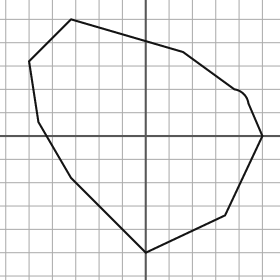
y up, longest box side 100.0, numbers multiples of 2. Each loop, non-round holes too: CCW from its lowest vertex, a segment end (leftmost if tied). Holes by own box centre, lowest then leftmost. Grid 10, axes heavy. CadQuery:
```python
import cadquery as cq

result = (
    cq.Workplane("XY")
    .moveTo(0.0, -50.0)
    .lineTo(34.0, -34.0)
    .lineTo(50.0, 0.0)
    .lineTo(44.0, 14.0)
    .threePointArc((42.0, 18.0), (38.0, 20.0))
    .lineTo(16.0, 36.0)
    .lineTo(-32.0, 50.0)
    .lineTo(-50.0, 32.0)
    .lineTo(-46.0, 6.0)
    .lineTo(-32.0, -18.0)
    .close()
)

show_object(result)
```